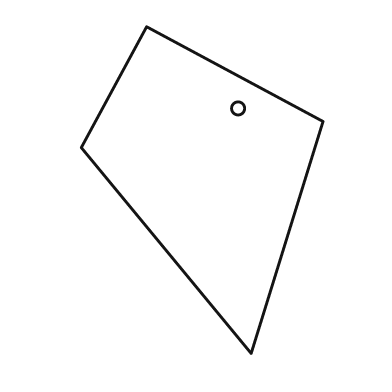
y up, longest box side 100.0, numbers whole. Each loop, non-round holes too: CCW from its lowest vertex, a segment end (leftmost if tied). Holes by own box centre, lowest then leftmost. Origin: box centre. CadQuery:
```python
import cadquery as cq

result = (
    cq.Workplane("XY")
    .moveTo(15.0, -50.0)
    .lineTo(37.0, 21.0)
    .lineTo(-17.0, 50.0)
    .lineTo(-37.0, 13.0)
    .close()
    .moveTo(11.0, 25.0)
    .circle(2.0)
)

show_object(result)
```